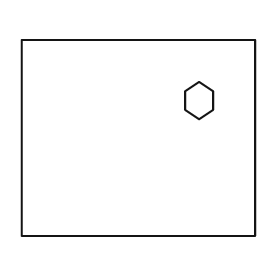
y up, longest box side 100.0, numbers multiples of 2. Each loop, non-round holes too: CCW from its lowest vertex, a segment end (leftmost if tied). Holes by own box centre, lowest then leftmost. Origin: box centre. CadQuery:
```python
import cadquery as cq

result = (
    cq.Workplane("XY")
    .moveTo(-50.0, -42.0)
    .lineTo(50.0, -42.0)
    .lineTo(50.0, 42.0)
    .lineTo(-50.0, 42.0)
    .close()
    .moveTo(26.0, 8.0)
    .lineTo(32.0, 12.0)
    .lineTo(32.0, 20.0)
    .lineTo(26.0, 24.0)
    .lineTo(20.0, 20.0)
    .lineTo(20.0, 12.0)
    .close()
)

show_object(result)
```